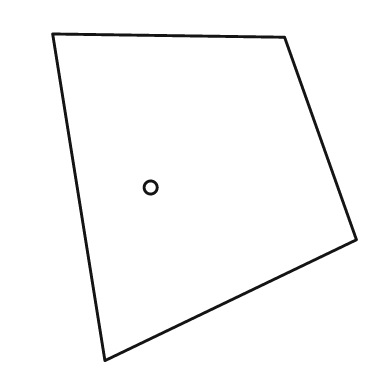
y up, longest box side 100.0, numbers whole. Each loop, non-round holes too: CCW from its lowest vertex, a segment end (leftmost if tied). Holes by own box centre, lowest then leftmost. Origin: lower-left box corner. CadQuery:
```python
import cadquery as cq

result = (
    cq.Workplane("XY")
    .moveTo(16.0, 0.0)
    .lineTo(93.0, 37.0)
    .lineTo(71.0, 99.0)
    .lineTo(0.0, 100.0)
    .close()
    .moveTo(30.0, 53.0)
    .circle(2.0)
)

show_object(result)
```